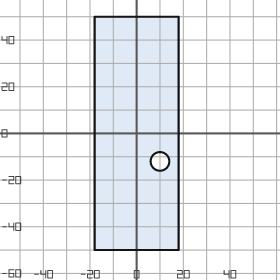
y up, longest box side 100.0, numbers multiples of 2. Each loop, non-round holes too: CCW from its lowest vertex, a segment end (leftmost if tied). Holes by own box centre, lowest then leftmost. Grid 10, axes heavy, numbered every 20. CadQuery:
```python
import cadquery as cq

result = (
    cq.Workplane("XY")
    .moveTo(-18.0, -50.0)
    .lineTo(18.0, -50.0)
    .lineTo(18.0, 50.0)
    .lineTo(-18.0, 50.0)
    .close()
    .moveTo(10.0, -12.0)
    .circle(4.0)
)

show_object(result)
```